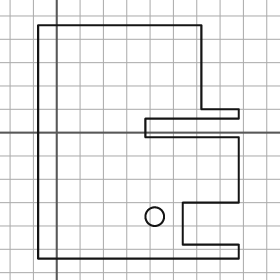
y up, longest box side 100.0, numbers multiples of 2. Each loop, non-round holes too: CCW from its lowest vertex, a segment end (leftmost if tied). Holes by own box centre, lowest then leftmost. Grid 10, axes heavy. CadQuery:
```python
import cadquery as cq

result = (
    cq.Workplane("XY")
    .moveTo(-8.0, -54.0)
    .lineTo(78.0, -54.0)
    .lineTo(78.0, -48.0)
    .lineTo(54.0, -48.0)
    .lineTo(54.0, -30.0)
    .lineTo(78.0, -30.0)
    .lineTo(78.0, -2.0)
    .lineTo(38.0, -2.0)
    .lineTo(38.0, 6.0)
    .lineTo(78.0, 6.0)
    .lineTo(78.0, 10.0)
    .lineTo(62.0, 10.0)
    .lineTo(62.0, 46.0)
    .lineTo(-8.0, 46.0)
    .close()
    .moveTo(42.0, -36.0)
    .circle(4.0)
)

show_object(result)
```